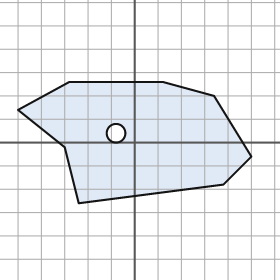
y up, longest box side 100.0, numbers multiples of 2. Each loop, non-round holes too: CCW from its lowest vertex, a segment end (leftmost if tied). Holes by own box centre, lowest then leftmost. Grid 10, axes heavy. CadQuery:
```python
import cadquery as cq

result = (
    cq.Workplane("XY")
    .moveTo(-24.0, -26.0)
    .lineTo(38.0, -18.0)
    .lineTo(50.0, -6.0)
    .lineTo(34.0, 20.0)
    .lineTo(12.0, 26.0)
    .lineTo(-28.0, 26.0)
    .lineTo(-50.0, 14.0)
    .lineTo(-30.0, -2.0)
    .close()
    .moveTo(-8.0, 4.0)
    .circle(4.0)
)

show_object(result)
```